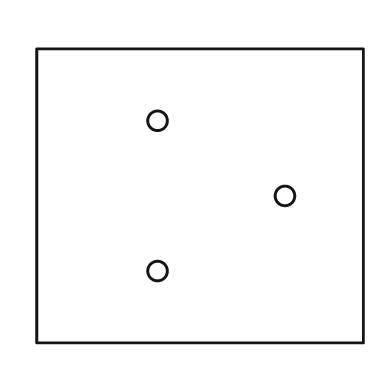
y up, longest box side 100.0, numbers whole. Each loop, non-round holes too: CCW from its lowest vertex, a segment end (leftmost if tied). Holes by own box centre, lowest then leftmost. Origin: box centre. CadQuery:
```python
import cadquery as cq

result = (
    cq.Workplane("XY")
    .moveTo(-50.0, -45.0)
    .lineTo(50.0, -45.0)
    .lineTo(50.0, 45.0)
    .lineTo(-50.0, 45.0)
    .close()
    .moveTo(-13.0, -23.0)
    .circle(3.0)
    .moveTo(26.0, 0.0)
    .circle(3.0)
    .moveTo(-13.0, 23.0)
    .circle(3.0)
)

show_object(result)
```